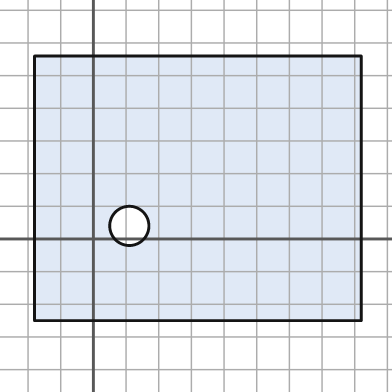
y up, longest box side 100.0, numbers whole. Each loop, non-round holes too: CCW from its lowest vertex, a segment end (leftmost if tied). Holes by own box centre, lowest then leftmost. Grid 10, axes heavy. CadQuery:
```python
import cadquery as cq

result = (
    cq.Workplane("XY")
    .moveTo(-18.0, -25.0)
    .lineTo(82.0, -25.0)
    .lineTo(82.0, 56.0)
    .lineTo(-18.0, 56.0)
    .close()
    .moveTo(11.0, 4.0)
    .circle(6.0)
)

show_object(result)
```